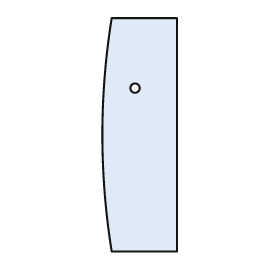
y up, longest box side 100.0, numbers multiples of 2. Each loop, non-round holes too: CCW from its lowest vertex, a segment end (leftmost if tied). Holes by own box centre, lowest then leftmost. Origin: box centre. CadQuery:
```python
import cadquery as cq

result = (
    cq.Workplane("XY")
    .moveTo(-12.0, -50.0)
    .lineTo(16.0, -50.0)
    .lineTo(16.0, 50.0)
    .lineTo(-12.0, 50.0)
    .threePointArc((-16.0, 0.0), (-12.0, -50.0))
    .close()
    .moveTo(-2.0, 20.0)
    .circle(2.0)
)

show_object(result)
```